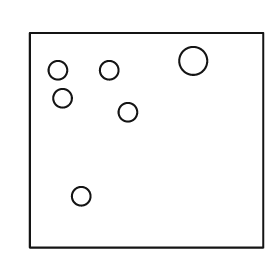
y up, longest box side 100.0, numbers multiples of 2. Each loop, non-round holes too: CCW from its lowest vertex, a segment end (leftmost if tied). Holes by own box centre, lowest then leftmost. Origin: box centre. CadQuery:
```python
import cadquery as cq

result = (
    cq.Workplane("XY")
    .moveTo(-50.0, -46.0)
    .lineTo(50.0, -46.0)
    .lineTo(50.0, 46.0)
    .lineTo(-50.0, 46.0)
    .close()
    .moveTo(-28.0, -24.0)
    .circle(4.0)
    .moveTo(-8.0, 12.0)
    .circle(4.0)
    .moveTo(-36.0, 18.0)
    .circle(4.0)
    .moveTo(-38.0, 30.0)
    .circle(4.0)
    .moveTo(-16.0, 30.0)
    .circle(4.0)
    .moveTo(20.0, 34.0)
    .circle(6.0)
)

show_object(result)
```